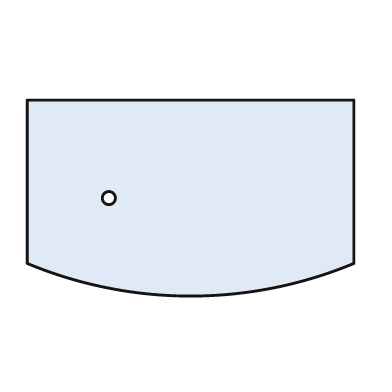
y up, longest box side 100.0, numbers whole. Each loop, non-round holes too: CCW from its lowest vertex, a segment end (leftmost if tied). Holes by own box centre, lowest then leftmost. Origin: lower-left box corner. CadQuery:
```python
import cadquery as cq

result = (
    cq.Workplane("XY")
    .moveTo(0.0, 10.0)
    .threePointArc((50.0, 0.0), (100.0, 10.0))
    .lineTo(100.0, 60.0)
    .lineTo(0.0, 60.0)
    .close()
    .moveTo(25.0, 30.0)
    .circle(2.0)
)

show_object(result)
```